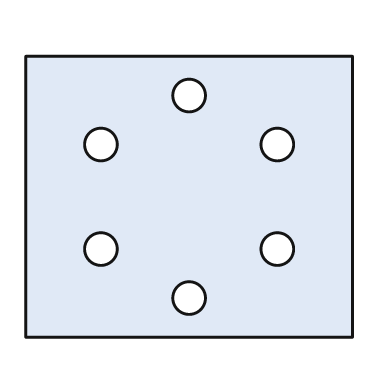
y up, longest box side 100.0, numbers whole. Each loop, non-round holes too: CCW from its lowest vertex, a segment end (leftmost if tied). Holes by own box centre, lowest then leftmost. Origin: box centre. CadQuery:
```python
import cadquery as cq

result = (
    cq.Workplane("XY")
    .moveTo(-50.0, -43.0)
    .lineTo(50.0, -43.0)
    .lineTo(50.0, 43.0)
    .lineTo(-50.0, 43.0)
    .close()
    .moveTo(0.0, -31.0)
    .circle(5.0)
    .moveTo(-27.0, -16.0)
    .circle(5.0)
    .moveTo(27.0, -16.0)
    .circle(5.0)
    .moveTo(-27.0, 16.0)
    .circle(5.0)
    .moveTo(27.0, 16.0)
    .circle(5.0)
    .moveTo(0.0, 31.0)
    .circle(5.0)
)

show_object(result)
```